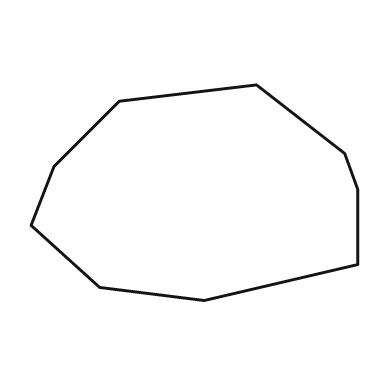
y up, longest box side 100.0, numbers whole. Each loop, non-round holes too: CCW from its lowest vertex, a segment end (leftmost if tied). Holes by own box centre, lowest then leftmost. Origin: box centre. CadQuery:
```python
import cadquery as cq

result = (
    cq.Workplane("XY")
    .moveTo(3.0, -33.0)
    .lineTo(50.0, -22.0)
    .lineTo(50.0, 1.0)
    .lineTo(46.0, 12.0)
    .lineTo(19.0, 33.0)
    .lineTo(-23.0, 28.0)
    .lineTo(-43.0, 8.0)
    .lineTo(-50.0, -10.0)
    .lineTo(-29.0, -29.0)
    .close()
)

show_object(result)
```